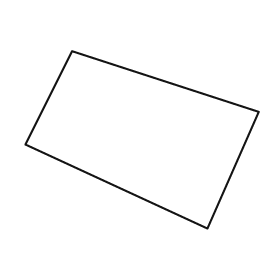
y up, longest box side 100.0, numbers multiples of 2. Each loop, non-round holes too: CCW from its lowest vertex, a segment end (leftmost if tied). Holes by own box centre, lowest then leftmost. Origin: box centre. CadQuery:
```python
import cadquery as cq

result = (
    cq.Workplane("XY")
    .moveTo(28.0, -38.0)
    .lineTo(50.0, 12.0)
    .lineTo(-30.0, 38.0)
    .lineTo(-50.0, -2.0)
    .close()
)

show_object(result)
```